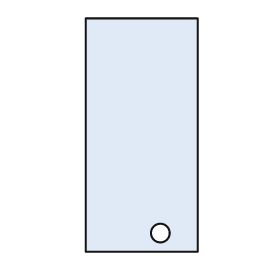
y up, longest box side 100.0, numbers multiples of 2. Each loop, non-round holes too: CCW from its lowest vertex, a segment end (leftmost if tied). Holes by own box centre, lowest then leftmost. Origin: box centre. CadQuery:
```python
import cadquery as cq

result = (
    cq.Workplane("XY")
    .moveTo(-24.0, -50.0)
    .lineTo(24.0, -50.0)
    .lineTo(24.0, 50.0)
    .lineTo(-24.0, 50.0)
    .close()
    .moveTo(8.0, -42.0)
    .circle(4.0)
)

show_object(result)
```